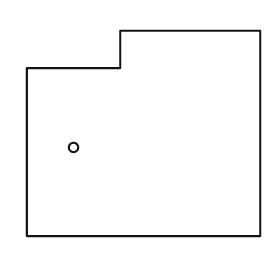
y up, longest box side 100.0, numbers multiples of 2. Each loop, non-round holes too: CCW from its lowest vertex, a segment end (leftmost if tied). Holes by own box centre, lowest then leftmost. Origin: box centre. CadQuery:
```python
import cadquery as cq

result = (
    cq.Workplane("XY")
    .moveTo(-50.0, -44.0)
    .lineTo(50.0, -44.0)
    .lineTo(50.0, 44.0)
    .lineTo(-10.0, 44.0)
    .lineTo(-10.0, 28.0)
    .lineTo(-50.0, 28.0)
    .close()
    .moveTo(-30.0, -6.0)
    .circle(2.0)
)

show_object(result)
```